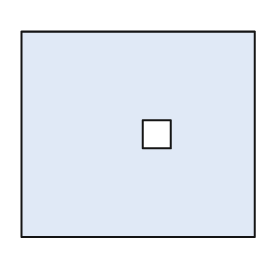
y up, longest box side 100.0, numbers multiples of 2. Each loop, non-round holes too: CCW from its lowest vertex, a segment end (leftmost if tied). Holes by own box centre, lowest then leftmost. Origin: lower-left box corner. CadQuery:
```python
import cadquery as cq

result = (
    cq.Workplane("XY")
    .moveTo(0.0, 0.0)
    .lineTo(100.0, 0.0)
    .lineTo(100.0, 88.0)
    .lineTo(0.0, 88.0)
    .close()
    .moveTo(52.0, 38.0)
    .lineTo(64.0, 38.0)
    .lineTo(64.0, 50.0)
    .lineTo(52.0, 50.0)
    .close()
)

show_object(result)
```